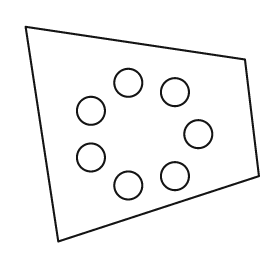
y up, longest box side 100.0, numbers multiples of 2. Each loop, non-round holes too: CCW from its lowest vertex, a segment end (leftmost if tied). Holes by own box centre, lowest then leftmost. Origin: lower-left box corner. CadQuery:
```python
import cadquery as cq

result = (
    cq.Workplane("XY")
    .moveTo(14.0, 0.0)
    .lineTo(100.0, 28.0)
    .lineTo(94.0, 78.0)
    .lineTo(0.0, 92.0)
    .close()
    .moveTo(44.0, 24.0)
    .circle(6.0)
    .moveTo(64.0, 28.0)
    .circle(6.0)
    .moveTo(28.0, 36.0)
    .circle(6.0)
    .moveTo(74.0, 46.0)
    .circle(6.0)
    .moveTo(28.0, 56.0)
    .circle(6.0)
    .moveTo(64.0, 64.0)
    .circle(6.0)
    .moveTo(44.0, 68.0)
    .circle(6.0)
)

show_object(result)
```